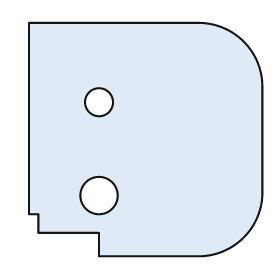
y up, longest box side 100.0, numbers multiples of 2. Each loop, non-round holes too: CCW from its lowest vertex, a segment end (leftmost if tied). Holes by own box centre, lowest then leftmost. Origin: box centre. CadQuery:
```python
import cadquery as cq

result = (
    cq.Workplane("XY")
    .moveTo(-20.0, -50.0)
    .lineTo(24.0, -50.0)
    .threePointArc((42.0, -42.0), (50.0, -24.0))
    .lineTo(50.0, 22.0)
    .threePointArc((42.0, 42.0), (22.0, 50.0))
    .lineTo(-50.0, 50.0)
    .lineTo(-50.0, -32.0)
    .lineTo(-46.0, -32.0)
    .lineTo(-46.0, -40.0)
    .lineTo(-20.0, -40.0)
    .close()
    .moveTo(-20.0, -24.0)
    .circle(8.0)
    .moveTo(-20.0, 16.0)
    .circle(6.0)
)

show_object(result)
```